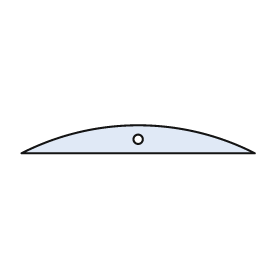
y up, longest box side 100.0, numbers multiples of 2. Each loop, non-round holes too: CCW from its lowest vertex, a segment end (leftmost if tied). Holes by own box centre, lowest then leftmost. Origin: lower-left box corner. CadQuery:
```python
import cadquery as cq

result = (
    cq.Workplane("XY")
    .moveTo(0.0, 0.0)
    .lineTo(100.0, 0.0)
    .threePointArc((50.0, 12.0), (0.0, 0.0))
    .close()
    .moveTo(50.0, 6.0)
    .circle(2.0)
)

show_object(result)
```